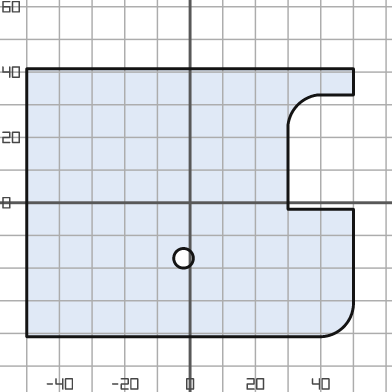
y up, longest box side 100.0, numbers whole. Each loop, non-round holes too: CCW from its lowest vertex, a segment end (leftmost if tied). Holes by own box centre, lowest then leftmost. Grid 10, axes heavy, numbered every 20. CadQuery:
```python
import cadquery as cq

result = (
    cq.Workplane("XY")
    .moveTo(-50.0, -41.0)
    .lineTo(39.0, -41.0)
    .threePointArc((47.0, -38.0), (50.0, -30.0))
    .lineTo(50.0, -2.0)
    .lineTo(30.0, -2.0)
    .lineTo(30.0, 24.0)
    .threePointArc((33.0, 30.0), (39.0, 33.0))
    .lineTo(50.0, 33.0)
    .lineTo(50.0, 41.0)
    .lineTo(-50.0, 41.0)
    .close()
    .moveTo(-2.0, -17.0)
    .circle(3.0)
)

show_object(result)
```